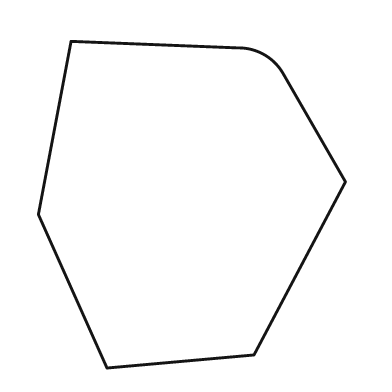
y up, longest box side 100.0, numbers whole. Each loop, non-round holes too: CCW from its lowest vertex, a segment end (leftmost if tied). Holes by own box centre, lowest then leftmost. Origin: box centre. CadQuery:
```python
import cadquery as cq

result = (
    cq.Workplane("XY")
    .moveTo(-26.0, -50.0)
    .lineTo(19.0, -46.0)
    .lineTo(47.0, 7.0)
    .lineTo(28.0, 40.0)
    .threePointArc((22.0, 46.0), (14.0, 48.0))
    .lineTo(-37.0, 50.0)
    .lineTo(-47.0, -3.0)
    .close()
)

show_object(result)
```